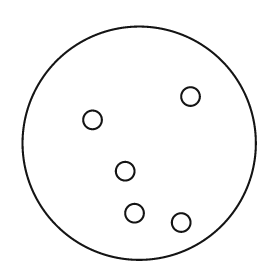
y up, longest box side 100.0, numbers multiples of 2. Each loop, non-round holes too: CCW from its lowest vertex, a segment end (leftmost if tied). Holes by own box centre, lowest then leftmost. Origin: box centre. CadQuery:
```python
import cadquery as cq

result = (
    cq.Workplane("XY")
    .moveTo(0.0, 0.0)
    .circle(50.0)
    .moveTo(18.0, -34.0)
    .circle(4.0)
    .moveTo(-2.0, -30.0)
    .circle(4.0)
    .moveTo(-6.0, -12.0)
    .circle(4.0)
    .moveTo(-20.0, 10.0)
    .circle(4.0)
    .moveTo(22.0, 20.0)
    .circle(4.0)
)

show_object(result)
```